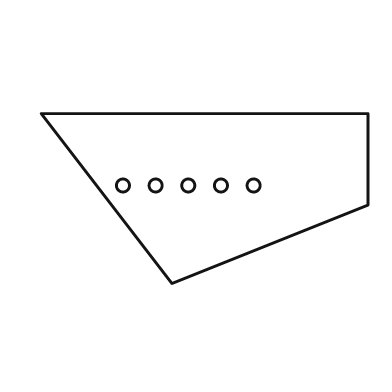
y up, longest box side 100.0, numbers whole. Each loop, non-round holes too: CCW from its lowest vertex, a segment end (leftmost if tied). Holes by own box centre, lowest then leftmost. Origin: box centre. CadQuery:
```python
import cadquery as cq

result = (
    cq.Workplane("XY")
    .moveTo(-10.0, -26.0)
    .lineTo(50.0, -2.0)
    .lineTo(50.0, 26.0)
    .lineTo(-50.0, 26.0)
    .close()
    .moveTo(-25.0, 4.0)
    .circle(2.0)
    .moveTo(-15.0, 4.0)
    .circle(2.0)
    .moveTo(-5.0, 4.0)
    .circle(2.0)
    .moveTo(5.0, 4.0)
    .circle(2.0)
    .moveTo(15.0, 4.0)
    .circle(2.0)
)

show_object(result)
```